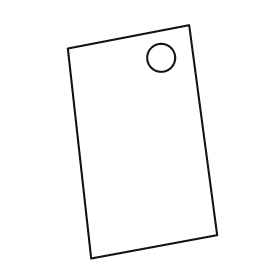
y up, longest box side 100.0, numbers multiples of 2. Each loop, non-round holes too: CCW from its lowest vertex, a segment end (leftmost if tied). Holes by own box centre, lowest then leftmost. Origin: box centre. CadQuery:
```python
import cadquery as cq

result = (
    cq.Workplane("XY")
    .moveTo(-22.0, -50.0)
    .lineTo(32.0, -40.0)
    .lineTo(20.0, 50.0)
    .lineTo(-32.0, 40.0)
    .close()
    .moveTo(8.0, 36.0)
    .circle(6.0)
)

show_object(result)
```